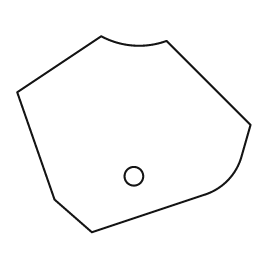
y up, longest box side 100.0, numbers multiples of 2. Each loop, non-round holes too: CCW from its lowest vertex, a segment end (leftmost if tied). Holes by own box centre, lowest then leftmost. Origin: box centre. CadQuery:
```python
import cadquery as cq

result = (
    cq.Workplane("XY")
    .moveTo(-18.0, -42.0)
    .lineTo(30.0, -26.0)
    .threePointArc((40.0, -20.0), (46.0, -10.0))
    .lineTo(50.0, 4.0)
    .lineTo(14.0, 40.0)
    .threePointArc((0.0, 38.0), (-14.0, 42.0))
    .lineTo(-50.0, 18.0)
    .lineTo(-34.0, -28.0)
    .close()
    .moveTo(0.0, -18.0)
    .circle(4.0)
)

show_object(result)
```